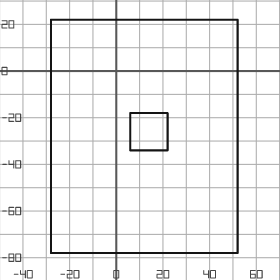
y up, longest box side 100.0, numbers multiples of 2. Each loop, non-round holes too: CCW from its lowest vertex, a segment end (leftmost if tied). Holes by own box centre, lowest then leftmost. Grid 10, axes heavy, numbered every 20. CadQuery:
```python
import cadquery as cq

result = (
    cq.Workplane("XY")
    .moveTo(-28.0, -78.0)
    .lineTo(52.0, -78.0)
    .lineTo(52.0, 22.0)
    .lineTo(-28.0, 22.0)
    .close()
    .moveTo(6.0, -34.0)
    .lineTo(22.0, -34.0)
    .lineTo(22.0, -18.0)
    .lineTo(6.0, -18.0)
    .close()
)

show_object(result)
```